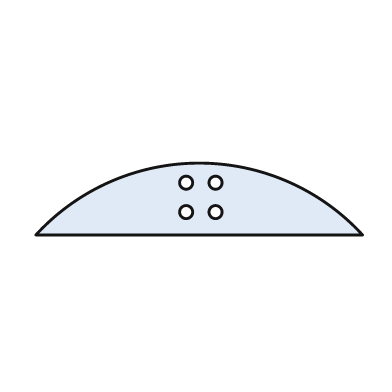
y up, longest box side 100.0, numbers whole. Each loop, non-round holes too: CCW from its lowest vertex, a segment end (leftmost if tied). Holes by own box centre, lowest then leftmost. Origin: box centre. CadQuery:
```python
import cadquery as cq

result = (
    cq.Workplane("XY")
    .moveTo(-50.0, -11.0)
    .lineTo(50.0, -11.0)
    .threePointArc((0.0, 11.0), (-50.0, -11.0))
    .close()
    .moveTo(-4.0, -4.0)
    .circle(2.0)
    .moveTo(5.0, -4.0)
    .circle(2.0)
    .moveTo(-4.0, 5.0)
    .circle(2.0)
    .moveTo(5.0, 5.0)
    .circle(2.0)
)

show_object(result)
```